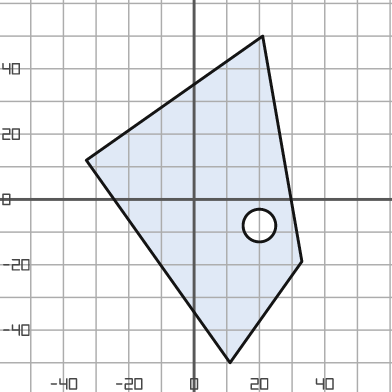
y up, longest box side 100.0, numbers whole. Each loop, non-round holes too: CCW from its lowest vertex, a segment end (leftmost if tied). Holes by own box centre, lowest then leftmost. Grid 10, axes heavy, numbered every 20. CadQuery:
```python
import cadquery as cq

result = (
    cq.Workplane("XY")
    .moveTo(11.0, -50.0)
    .lineTo(33.0, -19.0)
    .lineTo(21.0, 50.0)
    .lineTo(-33.0, 12.0)
    .close()
    .moveTo(20.0, -8.0)
    .circle(5.0)
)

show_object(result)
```